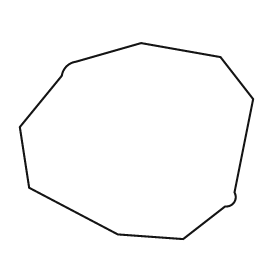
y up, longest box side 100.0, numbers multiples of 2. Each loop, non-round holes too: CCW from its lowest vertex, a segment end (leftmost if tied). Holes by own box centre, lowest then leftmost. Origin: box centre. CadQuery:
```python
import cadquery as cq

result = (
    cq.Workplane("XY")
    .moveTo(20.0, -42.0)
    .lineTo(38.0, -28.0)
    .threePointArc((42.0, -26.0), (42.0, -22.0))
    .lineTo(50.0, 18.0)
    .lineTo(36.0, 36.0)
    .lineTo(2.0, 42.0)
    .lineTo(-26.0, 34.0)
    .threePointArc((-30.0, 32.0), (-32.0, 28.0))
    .lineTo(-50.0, 6.0)
    .lineTo(-46.0, -20.0)
    .lineTo(-8.0, -40.0)
    .close()
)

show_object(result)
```